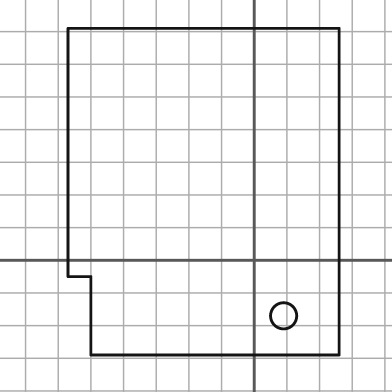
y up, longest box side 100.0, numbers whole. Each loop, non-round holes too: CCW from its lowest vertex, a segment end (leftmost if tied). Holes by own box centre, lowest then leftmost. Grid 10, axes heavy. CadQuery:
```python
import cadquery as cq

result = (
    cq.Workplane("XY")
    .moveTo(-50.0, -29.0)
    .lineTo(26.0, -29.0)
    .lineTo(26.0, 71.0)
    .lineTo(-57.0, 71.0)
    .lineTo(-57.0, -5.0)
    .lineTo(-50.0, -5.0)
    .close()
    .moveTo(9.0, -17.0)
    .circle(4.0)
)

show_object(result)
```